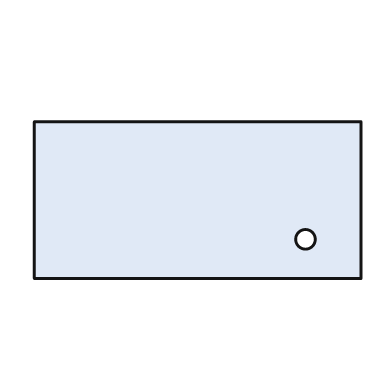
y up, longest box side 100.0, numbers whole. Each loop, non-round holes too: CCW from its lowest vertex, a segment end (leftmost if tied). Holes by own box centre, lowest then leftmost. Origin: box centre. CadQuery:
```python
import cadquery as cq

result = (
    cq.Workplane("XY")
    .moveTo(-50.0, -24.0)
    .lineTo(50.0, -24.0)
    .lineTo(50.0, 24.0)
    .lineTo(-50.0, 24.0)
    .close()
    .moveTo(33.0, -12.0)
    .circle(3.0)
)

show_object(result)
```